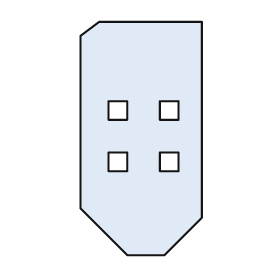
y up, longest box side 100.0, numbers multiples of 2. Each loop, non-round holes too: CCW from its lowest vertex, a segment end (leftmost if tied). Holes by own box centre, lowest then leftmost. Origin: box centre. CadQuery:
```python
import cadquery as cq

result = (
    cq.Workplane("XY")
    .moveTo(-6.0, -50.0)
    .lineTo(10.0, -50.0)
    .lineTo(26.0, -34.0)
    .lineTo(26.0, 50.0)
    .lineTo(-18.0, 50.0)
    .lineTo(-26.0, 44.0)
    .lineTo(-26.0, -30.0)
    .close()
    .moveTo(-14.0, -14.0)
    .lineTo(-6.0, -14.0)
    .lineTo(-6.0, -6.0)
    .lineTo(-14.0, -6.0)
    .close()
    .moveTo(8.0, -14.0)
    .lineTo(16.0, -14.0)
    .lineTo(16.0, -6.0)
    .lineTo(8.0, -6.0)
    .close()
    .moveTo(-14.0, 8.0)
    .lineTo(-6.0, 8.0)
    .lineTo(-6.0, 16.0)
    .lineTo(-14.0, 16.0)
    .close()
    .moveTo(8.0, 8.0)
    .lineTo(16.0, 8.0)
    .lineTo(16.0, 16.0)
    .lineTo(8.0, 16.0)
    .close()
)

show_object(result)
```